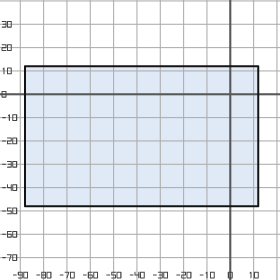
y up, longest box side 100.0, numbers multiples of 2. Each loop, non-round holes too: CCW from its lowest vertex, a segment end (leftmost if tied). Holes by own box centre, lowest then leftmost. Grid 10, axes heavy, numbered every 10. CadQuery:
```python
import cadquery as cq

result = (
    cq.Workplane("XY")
    .moveTo(-88.0, -48.0)
    .lineTo(12.0, -48.0)
    .lineTo(12.0, 12.0)
    .lineTo(-88.0, 12.0)
    .close()
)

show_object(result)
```